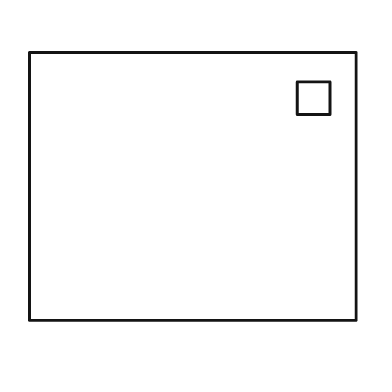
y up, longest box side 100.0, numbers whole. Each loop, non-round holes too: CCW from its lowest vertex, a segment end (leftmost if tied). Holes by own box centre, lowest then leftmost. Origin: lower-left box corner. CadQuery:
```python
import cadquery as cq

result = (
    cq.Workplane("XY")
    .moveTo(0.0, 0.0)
    .lineTo(100.0, 0.0)
    .lineTo(100.0, 82.0)
    .lineTo(0.0, 82.0)
    .close()
    .moveTo(82.0, 63.0)
    .lineTo(92.0, 63.0)
    .lineTo(92.0, 73.0)
    .lineTo(82.0, 73.0)
    .close()
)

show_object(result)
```